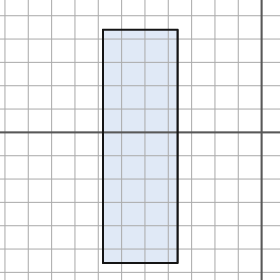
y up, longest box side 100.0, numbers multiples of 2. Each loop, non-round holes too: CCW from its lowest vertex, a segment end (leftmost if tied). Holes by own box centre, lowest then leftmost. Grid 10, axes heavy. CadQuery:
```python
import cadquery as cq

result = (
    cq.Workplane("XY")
    .moveTo(-68.0, -56.0)
    .lineTo(-36.0, -56.0)
    .lineTo(-36.0, 44.0)
    .lineTo(-68.0, 44.0)
    .close()
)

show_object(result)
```